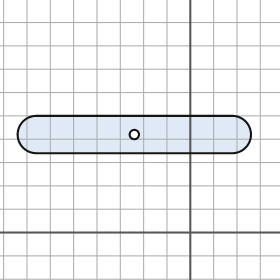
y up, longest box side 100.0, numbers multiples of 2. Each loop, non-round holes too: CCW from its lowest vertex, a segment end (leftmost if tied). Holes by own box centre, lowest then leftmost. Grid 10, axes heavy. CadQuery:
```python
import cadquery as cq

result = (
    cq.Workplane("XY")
    .moveTo(-66.0, 34.0)
    .lineTo(18.0, 34.0)
    .threePointArc((26.0, 42.0), (18.0, 50.0))
    .lineTo(-66.0, 50.0)
    .threePointArc((-74.0, 42.0), (-66.0, 34.0))
    .close()
    .moveTo(-24.0, 42.0)
    .circle(2.0)
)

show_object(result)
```